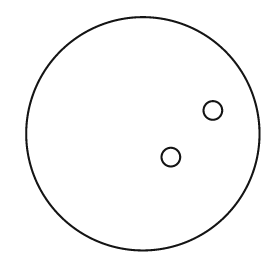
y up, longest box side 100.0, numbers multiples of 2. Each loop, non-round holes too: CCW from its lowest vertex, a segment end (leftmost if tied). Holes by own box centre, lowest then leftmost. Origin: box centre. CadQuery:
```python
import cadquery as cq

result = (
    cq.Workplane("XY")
    .moveTo(0.0, 0.0)
    .circle(50.0)
    .moveTo(12.0, -10.0)
    .circle(4.0)
    .moveTo(30.0, 10.0)
    .circle(4.0)
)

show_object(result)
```